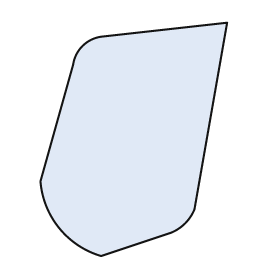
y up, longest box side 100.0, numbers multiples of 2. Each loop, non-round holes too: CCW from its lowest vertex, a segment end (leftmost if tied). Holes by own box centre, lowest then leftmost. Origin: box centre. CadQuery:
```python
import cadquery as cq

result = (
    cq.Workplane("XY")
    .moveTo(-14.0, -50.0)
    .lineTo(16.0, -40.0)
    .threePointArc((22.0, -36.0), (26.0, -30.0))
    .lineTo(40.0, 50.0)
    .lineTo(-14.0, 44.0)
    .threePointArc((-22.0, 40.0), (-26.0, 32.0))
    .lineTo(-40.0, -18.0)
    .threePointArc((-32.0, -38.0), (-14.0, -50.0))
    .close()
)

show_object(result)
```